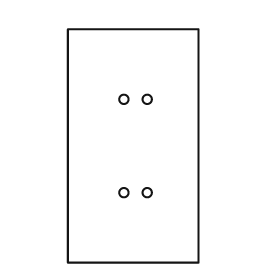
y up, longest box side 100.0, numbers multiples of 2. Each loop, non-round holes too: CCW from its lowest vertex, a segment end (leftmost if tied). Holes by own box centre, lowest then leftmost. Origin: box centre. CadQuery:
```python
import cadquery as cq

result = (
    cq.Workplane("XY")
    .moveTo(-28.0, -50.0)
    .lineTo(28.0, -50.0)
    .lineTo(28.0, 50.0)
    .lineTo(-28.0, 50.0)
    .close()
    .moveTo(-4.0, -20.0)
    .circle(2.0)
    .moveTo(6.0, -20.0)
    .circle(2.0)
    .moveTo(-4.0, 20.0)
    .circle(2.0)
    .moveTo(6.0, 20.0)
    .circle(2.0)
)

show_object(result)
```